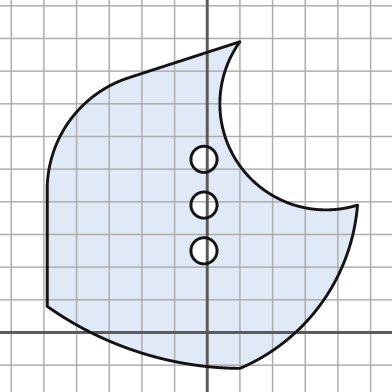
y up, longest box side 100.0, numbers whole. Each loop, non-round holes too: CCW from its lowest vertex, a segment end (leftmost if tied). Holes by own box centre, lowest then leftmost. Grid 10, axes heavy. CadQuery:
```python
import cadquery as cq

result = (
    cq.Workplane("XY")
    .moveTo(10.0, -11.0)
    .threePointArc((35.0, 9.0), (46.0, 39.0))
    .threePointArc((10.0, 51.0), (10.0, 89.0))
    .lineTo(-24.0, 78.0)
    .threePointArc((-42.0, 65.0), (-49.0, 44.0))
    .lineTo(-49.0, 8.0)
    .threePointArc((-21.0, -6.0), (10.0, -11.0))
    .close()
    .moveTo(-1.0, 25.0)
    .circle(4.0)
    .moveTo(-1.0, 39.0)
    .circle(4.0)
    .moveTo(-1.0, 53.0)
    .circle(4.0)
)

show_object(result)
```